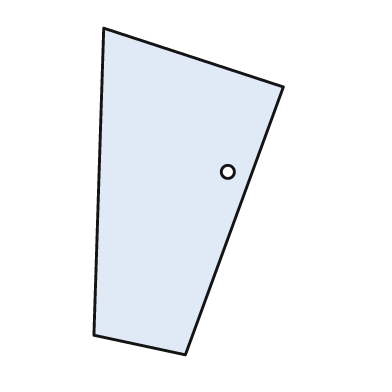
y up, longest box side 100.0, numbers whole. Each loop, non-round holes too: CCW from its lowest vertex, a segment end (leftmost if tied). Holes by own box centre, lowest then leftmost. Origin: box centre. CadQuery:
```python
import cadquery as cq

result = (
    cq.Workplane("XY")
    .moveTo(-1.0, -50.0)
    .lineTo(29.0, 32.0)
    .lineTo(-26.0, 50.0)
    .lineTo(-29.0, -44.0)
    .close()
    .moveTo(12.0, 6.0)
    .circle(2.0)
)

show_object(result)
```